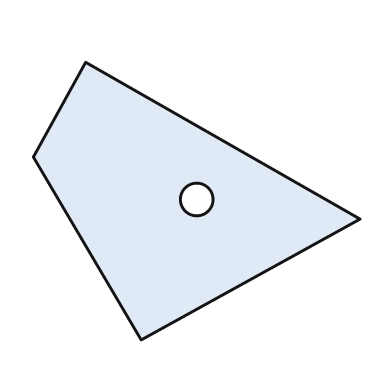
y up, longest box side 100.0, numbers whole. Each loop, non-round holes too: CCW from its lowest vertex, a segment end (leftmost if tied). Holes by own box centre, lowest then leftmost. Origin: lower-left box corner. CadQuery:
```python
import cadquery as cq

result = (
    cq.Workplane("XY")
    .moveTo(33.0, 0.0)
    .lineTo(100.0, 37.0)
    .lineTo(16.0, 85.0)
    .lineTo(0.0, 56.0)
    .close()
    .moveTo(50.0, 43.0)
    .circle(5.0)
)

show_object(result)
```